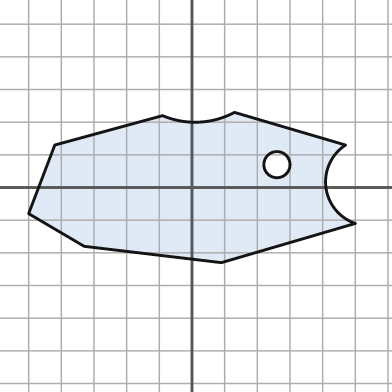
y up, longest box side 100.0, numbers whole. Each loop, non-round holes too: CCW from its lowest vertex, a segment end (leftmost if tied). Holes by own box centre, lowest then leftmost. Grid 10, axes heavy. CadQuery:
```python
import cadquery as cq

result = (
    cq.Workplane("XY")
    .moveTo(9.0, -23.0)
    .lineTo(50.0, -11.0)
    .threePointArc((41.0, 0.0), (47.0, 13.0))
    .lineTo(13.0, 23.0)
    .threePointArc((2.0, 20.0), (-9.0, 22.0))
    .lineTo(-42.0, 13.0)
    .lineTo(-50.0, -8.0)
    .lineTo(-33.0, -18.0)
    .close()
    .moveTo(26.0, 7.0)
    .circle(4.0)
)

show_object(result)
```